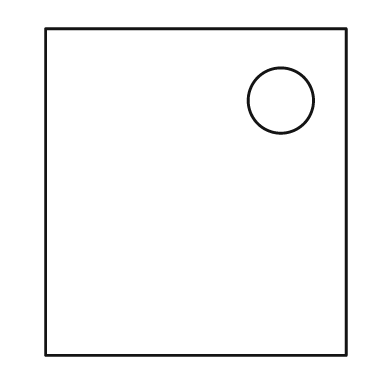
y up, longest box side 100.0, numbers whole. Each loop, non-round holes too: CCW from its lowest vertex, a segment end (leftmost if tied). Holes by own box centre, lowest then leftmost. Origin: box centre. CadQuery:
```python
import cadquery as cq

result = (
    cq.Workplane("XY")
    .moveTo(-46.0, -50.0)
    .lineTo(46.0, -50.0)
    .lineTo(46.0, 50.0)
    .lineTo(-46.0, 50.0)
    .close()
    .moveTo(26.0, 28.0)
    .circle(10.0)
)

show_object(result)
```